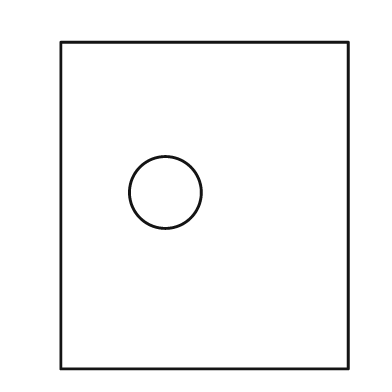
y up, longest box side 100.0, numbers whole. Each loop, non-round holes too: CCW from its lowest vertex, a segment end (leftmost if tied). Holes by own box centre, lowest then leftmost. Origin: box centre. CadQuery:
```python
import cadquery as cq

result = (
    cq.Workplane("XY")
    .moveTo(-44.0, -50.0)
    .lineTo(44.0, -50.0)
    .lineTo(44.0, 50.0)
    .lineTo(-44.0, 50.0)
    .close()
    .moveTo(-12.0, 4.0)
    .circle(11.0)
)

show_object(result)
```